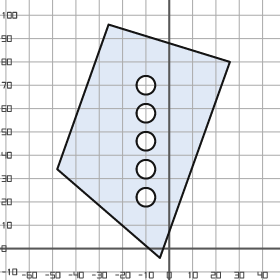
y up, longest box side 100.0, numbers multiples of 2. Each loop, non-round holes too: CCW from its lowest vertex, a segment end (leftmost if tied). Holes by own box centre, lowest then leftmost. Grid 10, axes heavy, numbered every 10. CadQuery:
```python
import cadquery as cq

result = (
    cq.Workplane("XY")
    .moveTo(-4.0, -4.0)
    .lineTo(26.0, 80.0)
    .lineTo(-26.0, 96.0)
    .lineTo(-48.0, 34.0)
    .close()
    .moveTo(-10.0, 22.0)
    .circle(4.0)
    .moveTo(-10.0, 34.0)
    .circle(4.0)
    .moveTo(-10.0, 46.0)
    .circle(4.0)
    .moveTo(-10.0, 58.0)
    .circle(4.0)
    .moveTo(-10.0, 70.0)
    .circle(4.0)
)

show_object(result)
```